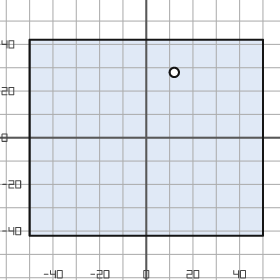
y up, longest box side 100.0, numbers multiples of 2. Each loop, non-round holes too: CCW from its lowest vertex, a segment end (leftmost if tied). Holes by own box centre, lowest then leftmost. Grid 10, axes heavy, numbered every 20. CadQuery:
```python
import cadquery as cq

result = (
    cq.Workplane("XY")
    .moveTo(-50.0, -42.0)
    .lineTo(50.0, -42.0)
    .lineTo(50.0, 42.0)
    .lineTo(-50.0, 42.0)
    .close()
    .moveTo(12.0, 28.0)
    .circle(2.0)
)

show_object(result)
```